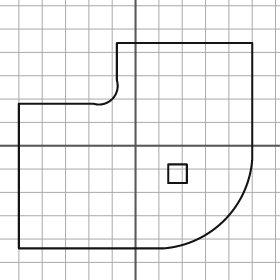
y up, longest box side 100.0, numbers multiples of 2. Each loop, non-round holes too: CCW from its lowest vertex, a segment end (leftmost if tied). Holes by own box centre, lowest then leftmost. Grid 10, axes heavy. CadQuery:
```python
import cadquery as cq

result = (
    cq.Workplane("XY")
    .moveTo(-50.0, -44.0)
    .lineTo(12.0, -44.0)
    .threePointArc((38.0, -32.0), (50.0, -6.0))
    .lineTo(50.0, 44.0)
    .lineTo(-8.0, 44.0)
    .lineTo(-8.0, 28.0)
    .threePointArc((-10.0, 20.0), (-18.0, 18.0))
    .lineTo(-50.0, 18.0)
    .close()
    .moveTo(14.0, -16.0)
    .lineTo(22.0, -16.0)
    .lineTo(22.0, -8.0)
    .lineTo(14.0, -8.0)
    .close()
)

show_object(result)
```